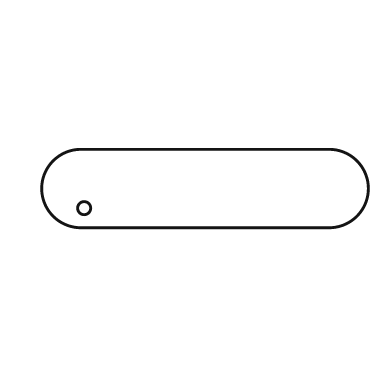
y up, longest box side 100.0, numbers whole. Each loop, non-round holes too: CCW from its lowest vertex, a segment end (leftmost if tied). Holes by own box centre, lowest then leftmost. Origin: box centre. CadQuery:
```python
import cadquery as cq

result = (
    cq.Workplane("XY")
    .moveTo(-38.0, -12.0)
    .lineTo(38.0, -12.0)
    .threePointArc((50.0, 0.0), (38.0, 12.0))
    .lineTo(-38.0, 12.0)
    .threePointArc((-50.0, 0.0), (-38.0, -12.0))
    .close()
    .moveTo(-37.0, -6.0)
    .circle(2.0)
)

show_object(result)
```